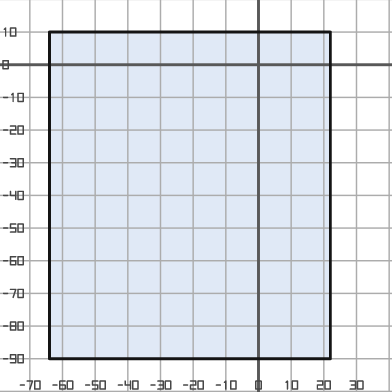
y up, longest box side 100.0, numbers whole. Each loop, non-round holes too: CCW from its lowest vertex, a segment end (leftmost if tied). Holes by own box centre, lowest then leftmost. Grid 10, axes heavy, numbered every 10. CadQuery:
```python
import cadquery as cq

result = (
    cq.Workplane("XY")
    .moveTo(-64.0, -90.0)
    .lineTo(22.0, -90.0)
    .lineTo(22.0, 10.0)
    .lineTo(-64.0, 10.0)
    .close()
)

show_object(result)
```